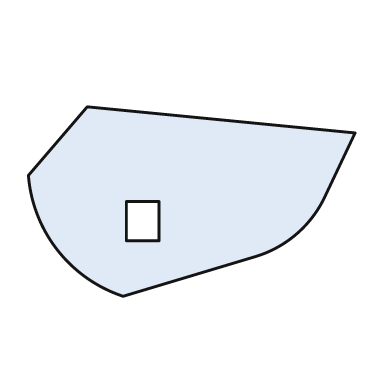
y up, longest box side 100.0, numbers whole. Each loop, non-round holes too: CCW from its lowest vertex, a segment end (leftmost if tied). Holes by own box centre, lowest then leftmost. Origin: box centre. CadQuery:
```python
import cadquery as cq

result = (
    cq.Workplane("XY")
    .moveTo(-21.0, -29.0)
    .lineTo(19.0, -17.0)
    .threePointArc((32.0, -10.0), (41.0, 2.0))
    .lineTo(50.0, 21.0)
    .lineTo(-32.0, 29.0)
    .lineTo(-50.0, 8.0)
    .threePointArc((-41.0, -15.0), (-21.0, -29.0))
    .close()
    .moveTo(-20.0, -12.0)
    .lineTo(-10.0, -12.0)
    .lineTo(-10.0, 0.0)
    .lineTo(-20.0, 0.0)
    .close()
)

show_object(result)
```